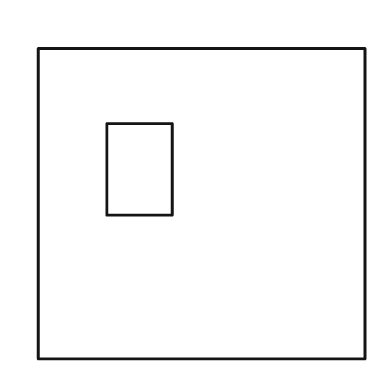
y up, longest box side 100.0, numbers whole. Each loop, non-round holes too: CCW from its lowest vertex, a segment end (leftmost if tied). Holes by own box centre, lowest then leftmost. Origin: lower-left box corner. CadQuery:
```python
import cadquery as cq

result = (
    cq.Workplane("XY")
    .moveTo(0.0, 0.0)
    .lineTo(100.0, 0.0)
    .lineTo(100.0, 95.0)
    .lineTo(0.0, 95.0)
    .close()
    .moveTo(21.0, 44.0)
    .lineTo(41.0, 44.0)
    .lineTo(41.0, 72.0)
    .lineTo(21.0, 72.0)
    .close()
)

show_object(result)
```